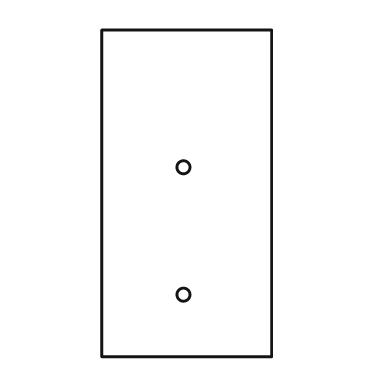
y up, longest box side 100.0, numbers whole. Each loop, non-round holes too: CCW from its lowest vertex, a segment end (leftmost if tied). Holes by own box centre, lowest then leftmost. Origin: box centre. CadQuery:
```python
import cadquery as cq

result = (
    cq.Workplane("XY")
    .moveTo(-26.0, -50.0)
    .lineTo(26.0, -50.0)
    .lineTo(26.0, 50.0)
    .lineTo(-26.0, 50.0)
    .close()
    .moveTo(-1.0, -31.0)
    .circle(2.0)
    .moveTo(-1.0, 8.0)
    .circle(2.0)
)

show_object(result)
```